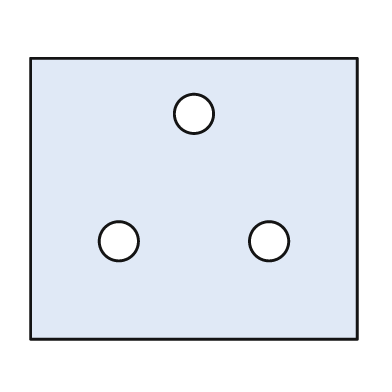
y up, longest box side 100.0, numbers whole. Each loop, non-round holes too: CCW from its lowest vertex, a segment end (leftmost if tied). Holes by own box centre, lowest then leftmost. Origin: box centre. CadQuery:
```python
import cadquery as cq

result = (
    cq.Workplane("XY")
    .moveTo(-50.0, -43.0)
    .lineTo(50.0, -43.0)
    .lineTo(50.0, 43.0)
    .lineTo(-50.0, 43.0)
    .close()
    .moveTo(-23.0, -13.0)
    .circle(6.0)
    .moveTo(23.0, -13.0)
    .circle(6.0)
    .moveTo(0.0, 26.0)
    .circle(6.0)
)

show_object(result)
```